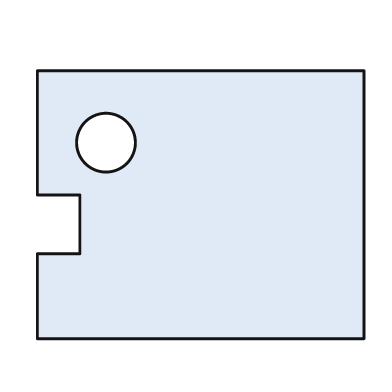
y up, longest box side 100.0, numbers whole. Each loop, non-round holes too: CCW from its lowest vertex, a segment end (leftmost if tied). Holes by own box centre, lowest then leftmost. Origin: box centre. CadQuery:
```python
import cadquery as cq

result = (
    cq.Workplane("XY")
    .moveTo(-50.0, -41.0)
    .lineTo(50.0, -41.0)
    .lineTo(50.0, 41.0)
    .lineTo(-50.0, 41.0)
    .lineTo(-50.0, 3.0)
    .lineTo(-37.0, 3.0)
    .lineTo(-37.0, -15.0)
    .lineTo(-50.0, -15.0)
    .close()
    .moveTo(-29.0, 19.0)
    .circle(9.0)
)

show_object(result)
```